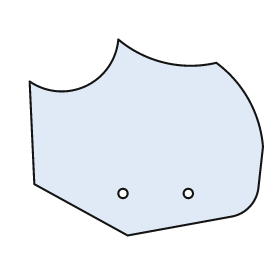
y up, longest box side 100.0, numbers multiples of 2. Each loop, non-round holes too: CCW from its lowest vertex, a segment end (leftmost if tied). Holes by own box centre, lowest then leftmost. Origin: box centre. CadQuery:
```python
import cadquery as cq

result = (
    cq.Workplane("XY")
    .moveTo(-8.0, -42.0)
    .lineTo(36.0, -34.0)
    .threePointArc((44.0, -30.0), (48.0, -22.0))
    .lineTo(50.0, -4.0)
    .threePointArc((44.0, 16.0), (30.0, 32.0))
    .threePointArc((8.0, 32.0), (-12.0, 42.0))
    .threePointArc((-26.0, 22.0), (-50.0, 24.0))
    .lineTo(-48.0, -20.0)
    .close()
    .moveTo(-10.0, -24.0)
    .circle(2.0)
    .moveTo(18.0, -24.0)
    .circle(2.0)
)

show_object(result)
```